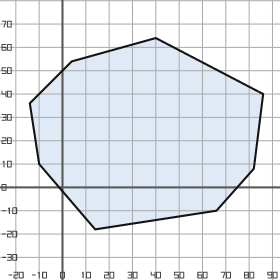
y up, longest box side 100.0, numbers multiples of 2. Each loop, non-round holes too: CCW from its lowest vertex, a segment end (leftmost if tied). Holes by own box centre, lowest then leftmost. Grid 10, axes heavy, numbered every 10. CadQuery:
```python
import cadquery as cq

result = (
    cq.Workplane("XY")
    .moveTo(14.0, -18.0)
    .lineTo(66.0, -10.0)
    .lineTo(82.0, 8.0)
    .lineTo(86.0, 40.0)
    .lineTo(40.0, 64.0)
    .lineTo(4.0, 54.0)
    .lineTo(-14.0, 36.0)
    .lineTo(-10.0, 10.0)
    .close()
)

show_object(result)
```